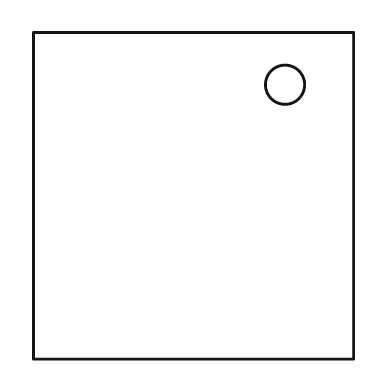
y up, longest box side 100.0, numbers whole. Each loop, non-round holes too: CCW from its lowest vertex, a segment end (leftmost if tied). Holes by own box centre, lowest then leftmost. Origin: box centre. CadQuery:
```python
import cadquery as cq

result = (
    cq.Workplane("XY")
    .moveTo(-49.0, -50.0)
    .lineTo(49.0, -50.0)
    .lineTo(49.0, 50.0)
    .lineTo(-49.0, 50.0)
    .close()
    .moveTo(28.0, 34.0)
    .circle(6.0)
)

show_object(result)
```